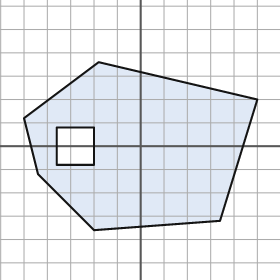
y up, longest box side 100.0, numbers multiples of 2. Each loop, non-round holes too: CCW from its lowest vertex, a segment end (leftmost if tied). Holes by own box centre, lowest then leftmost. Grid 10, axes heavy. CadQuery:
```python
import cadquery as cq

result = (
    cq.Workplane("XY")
    .moveTo(-20.0, -36.0)
    .lineTo(34.0, -32.0)
    .lineTo(50.0, 20.0)
    .lineTo(-18.0, 36.0)
    .lineTo(-50.0, 12.0)
    .lineTo(-44.0, -12.0)
    .close()
    .moveTo(-36.0, -8.0)
    .lineTo(-20.0, -8.0)
    .lineTo(-20.0, 8.0)
    .lineTo(-36.0, 8.0)
    .close()
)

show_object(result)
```